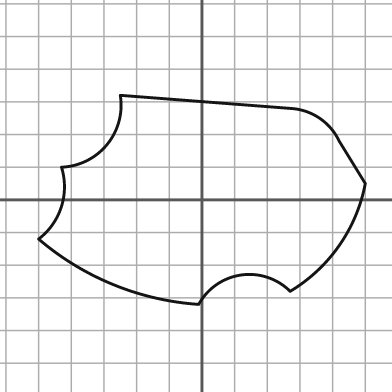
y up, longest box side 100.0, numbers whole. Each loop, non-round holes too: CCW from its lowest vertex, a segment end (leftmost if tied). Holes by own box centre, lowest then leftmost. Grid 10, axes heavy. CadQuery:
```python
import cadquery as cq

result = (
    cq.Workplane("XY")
    .moveTo(-1.0, -32.0)
    .threePointArc((12.0, -23.0), (27.0, -28.0))
    .threePointArc((42.0, -14.0), (50.0, 5.0))
    .lineTo(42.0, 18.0)
    .threePointArc((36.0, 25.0), (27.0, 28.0))
    .lineTo(-25.0, 32.0)
    .threePointArc((-29.0, 17.0), (-43.0, 10.0))
    .threePointArc((-43.0, -2.0), (-50.0, -12.0))
    .threePointArc((-27.0, -26.0), (-1.0, -32.0))
    .close()
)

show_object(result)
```